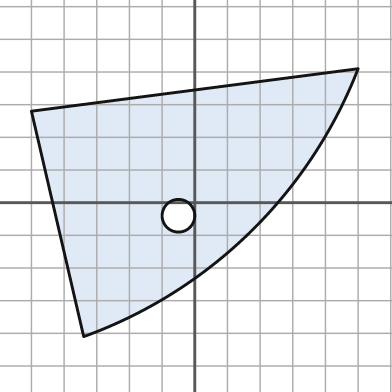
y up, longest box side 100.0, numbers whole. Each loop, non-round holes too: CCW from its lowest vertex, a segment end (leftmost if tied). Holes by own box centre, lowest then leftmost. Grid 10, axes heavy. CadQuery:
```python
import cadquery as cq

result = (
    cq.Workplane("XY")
    .moveTo(-34.0, -41.0)
    .threePointArc((17.0, -9.0), (50.0, 41.0))
    .lineTo(-50.0, 28.0)
    .close()
    .moveTo(-5.0, -4.0)
    .circle(5.0)
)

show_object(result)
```